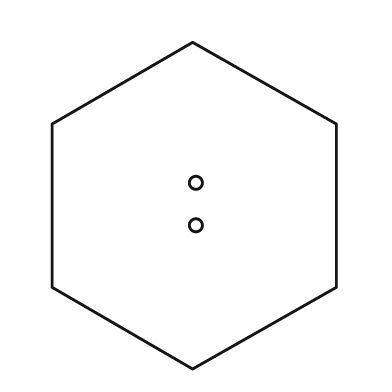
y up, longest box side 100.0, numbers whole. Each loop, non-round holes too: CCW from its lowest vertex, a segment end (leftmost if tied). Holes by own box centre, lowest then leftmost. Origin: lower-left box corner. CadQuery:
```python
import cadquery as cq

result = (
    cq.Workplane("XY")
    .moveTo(43.0, 0.0)
    .lineTo(87.0, 25.0)
    .lineTo(87.0, 75.0)
    .lineTo(43.0, 100.0)
    .lineTo(0.0, 75.0)
    .lineTo(0.0, 25.0)
    .close()
    .moveTo(44.0, 44.0)
    .circle(2.0)
    .moveTo(44.0, 57.0)
    .circle(2.0)
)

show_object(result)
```